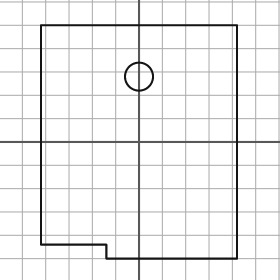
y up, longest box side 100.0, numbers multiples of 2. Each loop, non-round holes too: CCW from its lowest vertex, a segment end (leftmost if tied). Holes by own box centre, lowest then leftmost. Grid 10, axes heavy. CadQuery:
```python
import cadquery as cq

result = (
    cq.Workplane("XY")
    .moveTo(-14.0, -50.0)
    .lineTo(42.0, -50.0)
    .lineTo(42.0, 50.0)
    .lineTo(-42.0, 50.0)
    .lineTo(-42.0, -44.0)
    .lineTo(-14.0, -44.0)
    .close()
    .moveTo(0.0, 28.0)
    .circle(6.0)
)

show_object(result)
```